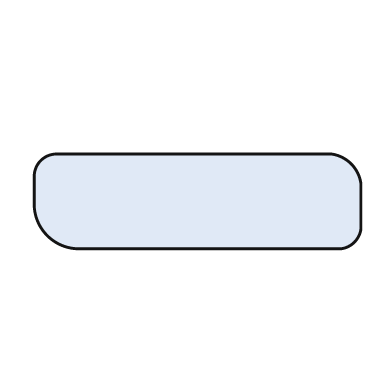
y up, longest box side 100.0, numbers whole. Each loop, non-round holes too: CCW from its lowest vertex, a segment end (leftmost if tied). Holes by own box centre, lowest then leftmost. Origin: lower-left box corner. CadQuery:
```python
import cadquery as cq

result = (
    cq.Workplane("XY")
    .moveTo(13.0, 0.0)
    .lineTo(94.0, 0.0)
    .threePointArc((98.0, 2.0), (100.0, 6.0))
    .lineTo(100.0, 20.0)
    .threePointArc((97.0, 26.0), (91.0, 29.0))
    .lineTo(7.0, 29.0)
    .threePointArc((2.0, 27.0), (0.0, 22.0))
    .lineTo(0.0, 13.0)
    .threePointArc((4.0, 4.0), (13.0, 0.0))
    .close()
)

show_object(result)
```